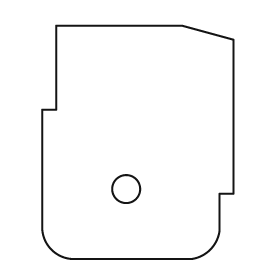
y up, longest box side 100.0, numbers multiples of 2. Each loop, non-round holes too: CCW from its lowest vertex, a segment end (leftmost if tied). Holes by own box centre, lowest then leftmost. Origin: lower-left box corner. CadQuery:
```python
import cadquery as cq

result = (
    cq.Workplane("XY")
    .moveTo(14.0, 0.0)
    .lineTo(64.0, 0.0)
    .threePointArc((72.0, 4.0), (76.0, 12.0))
    .lineTo(76.0, 28.0)
    .lineTo(82.0, 28.0)
    .lineTo(82.0, 94.0)
    .lineTo(60.0, 100.0)
    .lineTo(6.0, 100.0)
    .lineTo(6.0, 64.0)
    .lineTo(0.0, 64.0)
    .lineTo(0.0, 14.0)
    .threePointArc((4.0, 4.0), (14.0, 0.0))
    .close()
    .moveTo(36.0, 30.0)
    .circle(6.0)
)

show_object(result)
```